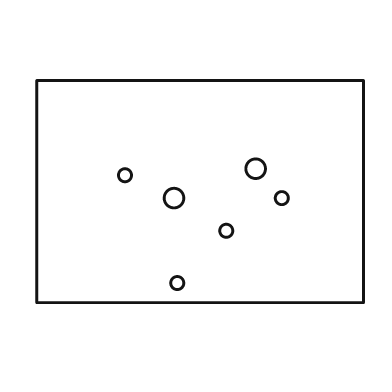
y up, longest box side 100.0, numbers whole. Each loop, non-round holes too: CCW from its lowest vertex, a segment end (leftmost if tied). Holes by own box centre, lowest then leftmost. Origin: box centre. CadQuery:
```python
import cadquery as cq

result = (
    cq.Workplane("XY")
    .moveTo(-50.0, -34.0)
    .lineTo(50.0, -34.0)
    .lineTo(50.0, 34.0)
    .lineTo(-50.0, 34.0)
    .close()
    .moveTo(-7.0, -28.0)
    .circle(2.0)
    .moveTo(8.0, -12.0)
    .circle(2.0)
    .moveTo(-8.0, -2.0)
    .circle(3.0)
    .moveTo(25.0, -2.0)
    .circle(2.0)
    .moveTo(-23.0, 5.0)
    .circle(2.0)
    .moveTo(17.0, 7.0)
    .circle(3.0)
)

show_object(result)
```